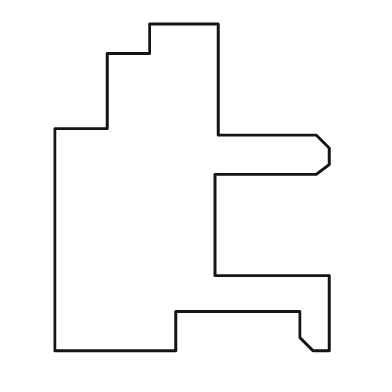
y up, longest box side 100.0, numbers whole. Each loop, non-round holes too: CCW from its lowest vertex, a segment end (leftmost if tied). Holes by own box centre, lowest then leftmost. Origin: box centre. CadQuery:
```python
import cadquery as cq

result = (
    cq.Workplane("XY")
    .moveTo(-42.0, -50.0)
    .lineTo(-5.0, -50.0)
    .lineTo(-5.0, -38.0)
    .lineTo(33.0, -38.0)
    .lineTo(33.0, -46.0)
    .lineTo(37.0, -50.0)
    .lineTo(42.0, -50.0)
    .lineTo(42.0, -27.0)
    .lineTo(7.0, -27.0)
    .lineTo(7.0, 4.0)
    .lineTo(38.0, 4.0)
    .lineTo(42.0, 7.0)
    .lineTo(42.0, 12.0)
    .lineTo(38.0, 16.0)
    .lineTo(8.0, 16.0)
    .lineTo(8.0, 50.0)
    .lineTo(-13.0, 50.0)
    .lineTo(-13.0, 41.0)
    .lineTo(-26.0, 41.0)
    .lineTo(-26.0, 18.0)
    .lineTo(-42.0, 18.0)
    .close()
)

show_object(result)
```